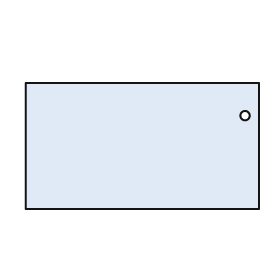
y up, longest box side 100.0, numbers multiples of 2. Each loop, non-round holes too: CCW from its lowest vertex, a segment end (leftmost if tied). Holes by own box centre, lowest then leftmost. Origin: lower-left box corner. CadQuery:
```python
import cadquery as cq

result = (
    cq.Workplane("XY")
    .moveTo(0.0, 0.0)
    .lineTo(100.0, 0.0)
    .lineTo(100.0, 54.0)
    .lineTo(0.0, 54.0)
    .close()
    .moveTo(94.0, 40.0)
    .circle(2.0)
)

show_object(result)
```